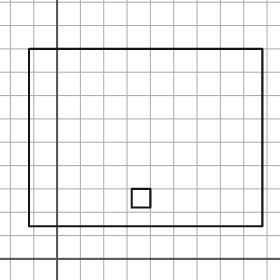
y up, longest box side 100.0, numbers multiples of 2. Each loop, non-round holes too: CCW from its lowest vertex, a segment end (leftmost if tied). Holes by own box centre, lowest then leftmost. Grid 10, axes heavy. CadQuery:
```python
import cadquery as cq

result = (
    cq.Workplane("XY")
    .moveTo(-12.0, 14.0)
    .lineTo(88.0, 14.0)
    .lineTo(88.0, 90.0)
    .lineTo(-12.0, 90.0)
    .close()
    .moveTo(32.0, 22.0)
    .lineTo(40.0, 22.0)
    .lineTo(40.0, 30.0)
    .lineTo(32.0, 30.0)
    .close()
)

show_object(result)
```